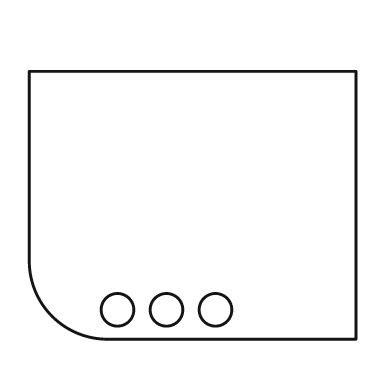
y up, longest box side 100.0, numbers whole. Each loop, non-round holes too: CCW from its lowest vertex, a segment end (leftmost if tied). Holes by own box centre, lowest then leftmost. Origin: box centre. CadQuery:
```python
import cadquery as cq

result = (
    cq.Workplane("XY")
    .moveTo(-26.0, -41.0)
    .lineTo(50.0, -41.0)
    .lineTo(50.0, 41.0)
    .lineTo(-50.0, 41.0)
    .lineTo(-50.0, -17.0)
    .threePointArc((-43.0, -34.0), (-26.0, -41.0))
    .close()
    .moveTo(-23.0, -32.0)
    .circle(5.0)
    .moveTo(-8.0, -32.0)
    .circle(5.0)
    .moveTo(7.0, -32.0)
    .circle(5.0)
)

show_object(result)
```